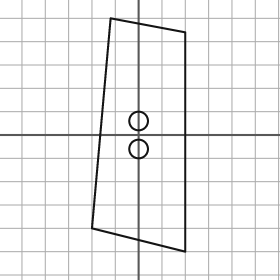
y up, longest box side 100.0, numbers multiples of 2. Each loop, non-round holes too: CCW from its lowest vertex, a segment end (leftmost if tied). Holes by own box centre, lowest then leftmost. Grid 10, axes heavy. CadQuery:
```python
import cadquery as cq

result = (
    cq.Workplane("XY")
    .moveTo(20.0, -50.0)
    .lineTo(20.0, 44.0)
    .lineTo(-12.0, 50.0)
    .lineTo(-20.0, -40.0)
    .close()
    .moveTo(0.0, -6.0)
    .circle(4.0)
    .moveTo(0.0, 6.0)
    .circle(4.0)
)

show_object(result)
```